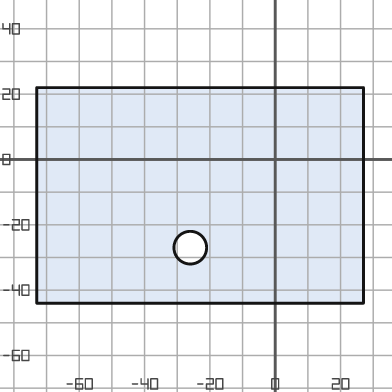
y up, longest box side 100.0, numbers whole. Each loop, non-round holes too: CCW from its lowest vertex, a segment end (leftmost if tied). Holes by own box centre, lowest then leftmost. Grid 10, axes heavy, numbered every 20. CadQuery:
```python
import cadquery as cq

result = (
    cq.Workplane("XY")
    .moveTo(-73.0, -44.0)
    .lineTo(27.0, -44.0)
    .lineTo(27.0, 22.0)
    .lineTo(-73.0, 22.0)
    .close()
    .moveTo(-26.0, -27.0)
    .circle(5.0)
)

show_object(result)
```